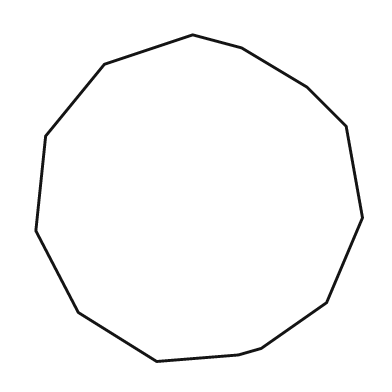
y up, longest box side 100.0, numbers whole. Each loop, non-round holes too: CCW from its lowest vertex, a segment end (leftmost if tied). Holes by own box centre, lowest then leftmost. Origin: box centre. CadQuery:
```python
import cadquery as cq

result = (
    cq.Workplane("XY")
    .moveTo(-13.0, -50.0)
    .lineTo(12.0, -48.0)
    .lineTo(19.0, -46.0)
    .lineTo(39.0, -32.0)
    .lineTo(50.0, -6.0)
    .lineTo(45.0, 22.0)
    .lineTo(33.0, 34.0)
    .lineTo(13.0, 46.0)
    .lineTo(-2.0, 50.0)
    .lineTo(-29.0, 41.0)
    .lineTo(-47.0, 19.0)
    .lineTo(-50.0, -10.0)
    .lineTo(-37.0, -35.0)
    .close()
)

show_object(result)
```